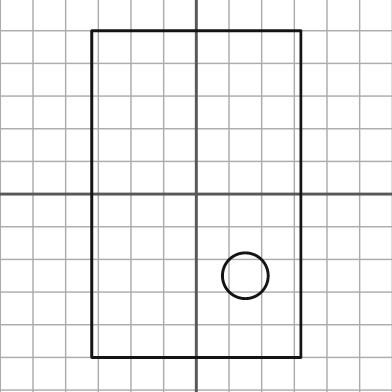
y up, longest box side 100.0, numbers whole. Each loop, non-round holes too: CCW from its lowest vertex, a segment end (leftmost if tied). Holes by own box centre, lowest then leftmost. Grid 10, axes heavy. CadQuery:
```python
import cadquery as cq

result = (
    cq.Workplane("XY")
    .moveTo(-32.0, -50.0)
    .lineTo(32.0, -50.0)
    .lineTo(32.0, 50.0)
    .lineTo(-32.0, 50.0)
    .close()
    .moveTo(15.0, -25.0)
    .circle(7.0)
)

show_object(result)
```